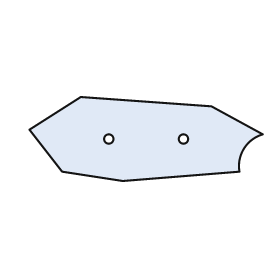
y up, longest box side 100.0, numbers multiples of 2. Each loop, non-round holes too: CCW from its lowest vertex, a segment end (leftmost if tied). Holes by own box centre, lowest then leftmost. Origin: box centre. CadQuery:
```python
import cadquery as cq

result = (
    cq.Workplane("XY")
    .moveTo(-10.0, -18.0)
    .lineTo(40.0, -14.0)
    .threePointArc((42.0, -4.0), (50.0, 2.0))
    .lineTo(28.0, 14.0)
    .lineTo(-28.0, 18.0)
    .lineTo(-50.0, 4.0)
    .lineTo(-36.0, -14.0)
    .close()
    .moveTo(-16.0, 0.0)
    .circle(2.0)
    .moveTo(16.0, 0.0)
    .circle(2.0)
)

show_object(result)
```